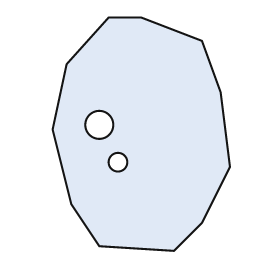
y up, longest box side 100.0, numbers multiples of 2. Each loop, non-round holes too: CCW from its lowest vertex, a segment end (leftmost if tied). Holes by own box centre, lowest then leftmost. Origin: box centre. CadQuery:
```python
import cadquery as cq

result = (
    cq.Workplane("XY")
    .moveTo(14.0, -50.0)
    .lineTo(26.0, -38.0)
    .lineTo(38.0, -14.0)
    .lineTo(34.0, 18.0)
    .lineTo(26.0, 40.0)
    .lineTo(0.0, 50.0)
    .lineTo(-14.0, 50.0)
    .lineTo(-32.0, 30.0)
    .lineTo(-38.0, 2.0)
    .lineTo(-30.0, -30.0)
    .lineTo(-18.0, -48.0)
    .close()
    .moveTo(-10.0, -12.0)
    .circle(4.0)
    .moveTo(-18.0, 4.0)
    .circle(6.0)
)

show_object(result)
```